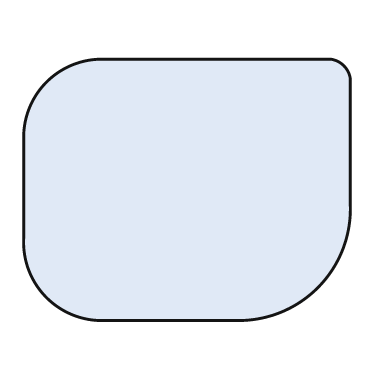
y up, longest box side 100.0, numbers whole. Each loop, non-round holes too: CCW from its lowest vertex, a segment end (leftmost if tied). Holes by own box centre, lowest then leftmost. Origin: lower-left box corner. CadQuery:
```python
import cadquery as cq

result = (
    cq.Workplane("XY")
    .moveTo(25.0, 0.0)
    .lineTo(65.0, 0.0)
    .threePointArc((90.0, 10.0), (100.0, 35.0))
    .lineTo(100.0, 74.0)
    .threePointArc((98.0, 78.0), (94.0, 80.0))
    .lineTo(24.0, 80.0)
    .threePointArc((7.0, 73.0), (0.0, 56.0))
    .lineTo(0.0, 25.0)
    .threePointArc((7.0, 7.0), (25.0, 0.0))
    .close()
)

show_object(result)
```